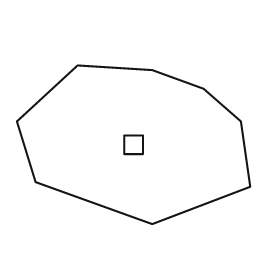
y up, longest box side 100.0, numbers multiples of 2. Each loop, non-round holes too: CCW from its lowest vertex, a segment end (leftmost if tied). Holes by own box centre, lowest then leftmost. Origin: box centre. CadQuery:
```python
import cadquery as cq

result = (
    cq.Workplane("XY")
    .moveTo(8.0, -34.0)
    .lineTo(50.0, -18.0)
    .lineTo(46.0, 10.0)
    .lineTo(30.0, 24.0)
    .lineTo(8.0, 32.0)
    .lineTo(-24.0, 34.0)
    .lineTo(-50.0, 10.0)
    .lineTo(-42.0, -16.0)
    .close()
    .moveTo(-4.0, -4.0)
    .lineTo(4.0, -4.0)
    .lineTo(4.0, 4.0)
    .lineTo(-4.0, 4.0)
    .close()
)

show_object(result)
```